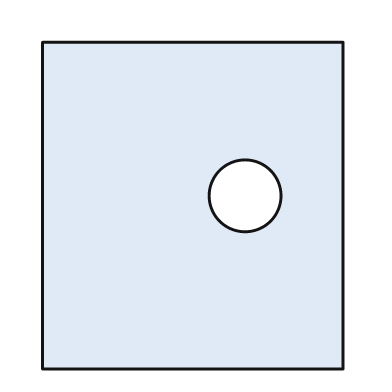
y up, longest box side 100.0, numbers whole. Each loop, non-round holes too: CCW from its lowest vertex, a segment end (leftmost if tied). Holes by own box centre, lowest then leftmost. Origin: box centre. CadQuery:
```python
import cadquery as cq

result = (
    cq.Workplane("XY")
    .moveTo(-46.0, -50.0)
    .lineTo(46.0, -50.0)
    .lineTo(46.0, 50.0)
    .lineTo(-46.0, 50.0)
    .close()
    .moveTo(16.0, 3.0)
    .circle(11.0)
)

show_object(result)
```